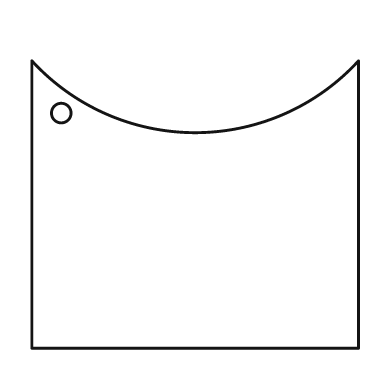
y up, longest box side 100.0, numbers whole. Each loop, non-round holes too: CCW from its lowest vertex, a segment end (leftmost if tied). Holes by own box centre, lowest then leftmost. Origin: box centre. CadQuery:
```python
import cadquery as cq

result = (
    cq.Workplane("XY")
    .moveTo(-50.0, -44.0)
    .lineTo(50.0, -44.0)
    .lineTo(50.0, 44.0)
    .threePointArc((0.0, 22.0), (-50.0, 44.0))
    .close()
    .moveTo(-41.0, 28.0)
    .circle(3.0)
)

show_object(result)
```